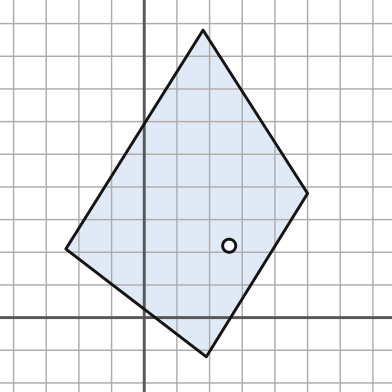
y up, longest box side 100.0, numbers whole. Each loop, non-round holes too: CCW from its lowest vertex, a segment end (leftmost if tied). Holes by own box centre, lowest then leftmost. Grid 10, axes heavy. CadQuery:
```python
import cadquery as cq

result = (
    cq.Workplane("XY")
    .moveTo(19.0, -12.0)
    .lineTo(50.0, 38.0)
    .lineTo(18.0, 88.0)
    .lineTo(-24.0, 21.0)
    .close()
    .moveTo(26.0, 22.0)
    .circle(2.0)
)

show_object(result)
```